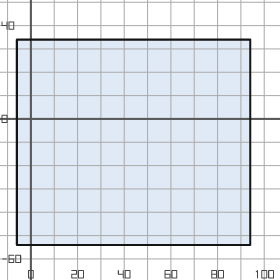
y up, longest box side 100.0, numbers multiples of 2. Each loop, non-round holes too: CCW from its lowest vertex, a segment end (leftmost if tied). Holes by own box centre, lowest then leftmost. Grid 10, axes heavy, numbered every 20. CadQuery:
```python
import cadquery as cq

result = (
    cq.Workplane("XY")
    .moveTo(-6.0, -54.0)
    .lineTo(94.0, -54.0)
    .lineTo(94.0, 34.0)
    .lineTo(-6.0, 34.0)
    .close()
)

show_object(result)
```